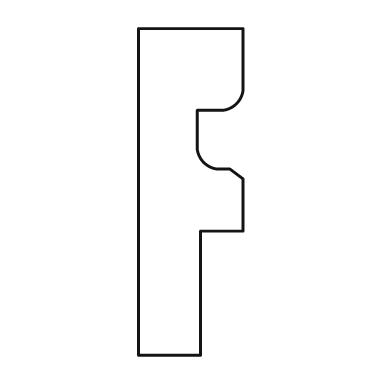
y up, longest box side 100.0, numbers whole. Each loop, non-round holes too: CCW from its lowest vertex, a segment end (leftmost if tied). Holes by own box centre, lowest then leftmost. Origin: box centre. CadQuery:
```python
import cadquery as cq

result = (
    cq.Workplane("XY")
    .moveTo(-16.0, -50.0)
    .lineTo(3.0, -50.0)
    .lineTo(3.0, -12.0)
    .lineTo(16.0, -12.0)
    .lineTo(16.0, 4.0)
    .lineTo(12.0, 7.0)
    .lineTo(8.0, 7.0)
    .threePointArc((4.0, 9.0), (2.0, 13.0))
    .lineTo(2.0, 25.0)
    .lineTo(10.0, 25.0)
    .threePointArc((14.0, 27.0), (16.0, 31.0))
    .lineTo(16.0, 50.0)
    .lineTo(-16.0, 50.0)
    .close()
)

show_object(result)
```